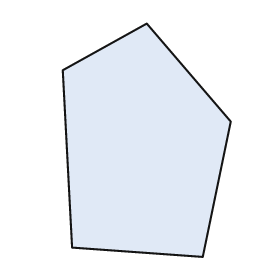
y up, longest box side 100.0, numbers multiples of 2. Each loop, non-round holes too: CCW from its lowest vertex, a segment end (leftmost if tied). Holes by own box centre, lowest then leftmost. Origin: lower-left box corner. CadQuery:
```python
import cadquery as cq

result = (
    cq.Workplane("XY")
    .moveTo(60.0, 0.0)
    .lineTo(72.0, 58.0)
    .lineTo(36.0, 100.0)
    .lineTo(0.0, 80.0)
    .lineTo(4.0, 4.0)
    .close()
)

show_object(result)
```